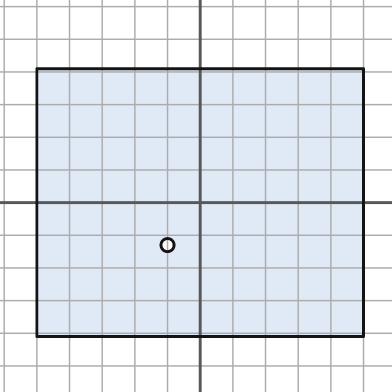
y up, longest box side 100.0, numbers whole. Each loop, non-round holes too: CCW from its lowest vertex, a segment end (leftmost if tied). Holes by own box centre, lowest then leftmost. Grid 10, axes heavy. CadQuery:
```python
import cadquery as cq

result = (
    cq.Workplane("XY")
    .moveTo(-50.0, -41.0)
    .lineTo(50.0, -41.0)
    .lineTo(50.0, 41.0)
    .lineTo(-50.0, 41.0)
    .close()
    .moveTo(-10.0, -13.0)
    .circle(2.0)
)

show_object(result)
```